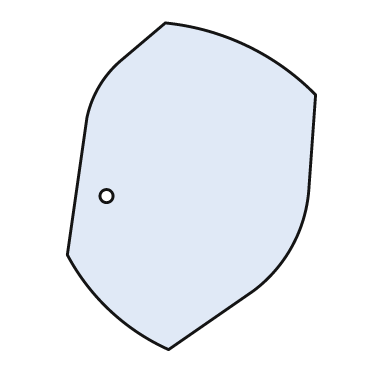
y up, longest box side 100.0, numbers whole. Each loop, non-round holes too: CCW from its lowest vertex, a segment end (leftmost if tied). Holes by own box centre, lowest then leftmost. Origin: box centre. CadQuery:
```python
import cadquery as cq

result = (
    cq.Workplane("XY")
    .moveTo(-7.0, -50.0)
    .lineTo(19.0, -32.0)
    .threePointArc((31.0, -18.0), (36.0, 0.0))
    .lineTo(38.0, 28.0)
    .threePointArc((17.0, 43.0), (-8.0, 50.0))
    .lineTo(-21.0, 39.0)
    .threePointArc((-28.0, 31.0), (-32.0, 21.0))
    .lineTo(-38.0, -21.0)
    .threePointArc((-25.0, -38.0), (-7.0, -50.0))
    .close()
    .moveTo(-26.0, -3.0)
    .circle(2.0)
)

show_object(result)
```